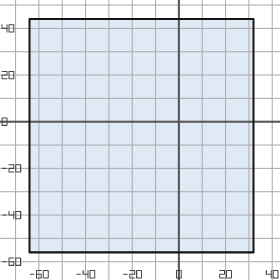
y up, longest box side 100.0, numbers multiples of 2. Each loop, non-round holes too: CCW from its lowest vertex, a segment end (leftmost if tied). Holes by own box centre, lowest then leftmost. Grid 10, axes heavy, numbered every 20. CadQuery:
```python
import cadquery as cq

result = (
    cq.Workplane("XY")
    .moveTo(-64.0, -56.0)
    .lineTo(32.0, -56.0)
    .lineTo(32.0, 44.0)
    .lineTo(-64.0, 44.0)
    .close()
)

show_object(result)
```